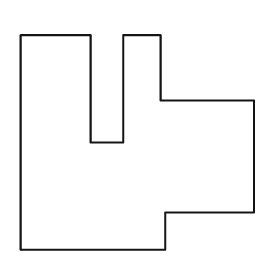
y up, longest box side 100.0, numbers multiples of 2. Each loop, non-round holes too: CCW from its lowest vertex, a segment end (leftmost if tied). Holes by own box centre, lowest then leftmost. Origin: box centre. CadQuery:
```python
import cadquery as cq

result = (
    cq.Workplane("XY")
    .moveTo(-50.0, -46.0)
    .lineTo(12.0, -46.0)
    .lineTo(12.0, -30.0)
    .lineTo(50.0, -30.0)
    .lineTo(50.0, 18.0)
    .lineTo(10.0, 18.0)
    .lineTo(10.0, 46.0)
    .lineTo(-6.0, 46.0)
    .lineTo(-6.0, 0.0)
    .lineTo(-20.0, 0.0)
    .lineTo(-20.0, 46.0)
    .lineTo(-50.0, 46.0)
    .close()
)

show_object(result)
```